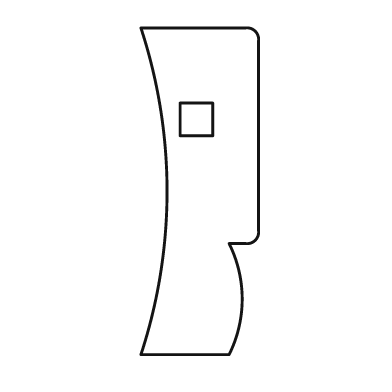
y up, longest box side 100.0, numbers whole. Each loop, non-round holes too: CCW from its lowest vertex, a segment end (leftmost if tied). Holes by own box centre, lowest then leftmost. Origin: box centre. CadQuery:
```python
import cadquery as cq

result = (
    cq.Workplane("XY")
    .moveTo(-18.0, -50.0)
    .lineTo(9.0, -50.0)
    .threePointArc((13.0, -33.0), (9.0, -16.0))
    .lineTo(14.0, -16.0)
    .threePointArc((17.0, -15.0), (18.0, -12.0))
    .lineTo(18.0, 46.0)
    .threePointArc((17.0, 49.0), (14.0, 50.0))
    .lineTo(-18.0, 50.0)
    .threePointArc((-10.0, 0.0), (-18.0, -50.0))
    .close()
    .moveTo(-6.0, 17.0)
    .lineTo(4.0, 17.0)
    .lineTo(4.0, 27.0)
    .lineTo(-6.0, 27.0)
    .close()
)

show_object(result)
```